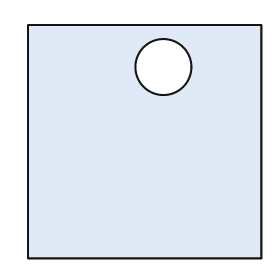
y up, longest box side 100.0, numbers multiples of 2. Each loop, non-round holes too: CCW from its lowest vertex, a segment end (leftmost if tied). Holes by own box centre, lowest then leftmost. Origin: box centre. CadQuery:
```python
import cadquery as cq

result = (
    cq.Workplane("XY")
    .moveTo(-50.0, -50.0)
    .lineTo(50.0, -50.0)
    .lineTo(50.0, 50.0)
    .lineTo(-50.0, 50.0)
    .close()
    .moveTo(8.0, 32.0)
    .circle(12.0)
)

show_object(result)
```